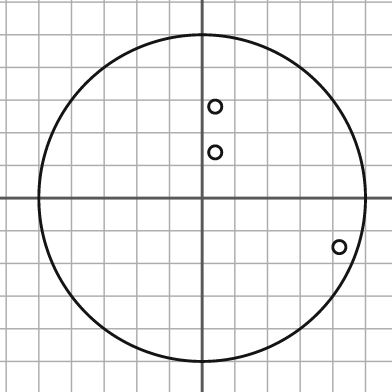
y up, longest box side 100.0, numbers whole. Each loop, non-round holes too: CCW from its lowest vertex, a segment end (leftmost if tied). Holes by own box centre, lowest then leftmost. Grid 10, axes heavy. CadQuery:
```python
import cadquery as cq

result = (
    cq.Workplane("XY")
    .moveTo(0.0, 0.0)
    .circle(50.0)
    .moveTo(42.0, -15.0)
    .circle(2.0)
    .moveTo(4.0, 14.0)
    .circle(2.0)
    .moveTo(4.0, 28.0)
    .circle(2.0)
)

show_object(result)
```